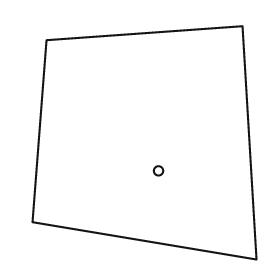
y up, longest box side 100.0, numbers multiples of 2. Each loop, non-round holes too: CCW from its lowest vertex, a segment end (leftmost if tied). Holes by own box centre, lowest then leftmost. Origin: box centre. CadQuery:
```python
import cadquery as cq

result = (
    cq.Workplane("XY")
    .moveTo(48.0, -50.0)
    .lineTo(42.0, 50.0)
    .lineTo(-42.0, 44.0)
    .lineTo(-48.0, -34.0)
    .close()
    .moveTo(6.0, -12.0)
    .circle(2.0)
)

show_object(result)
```